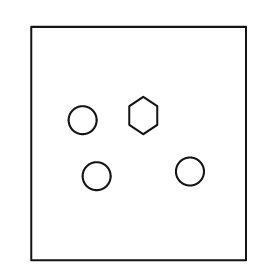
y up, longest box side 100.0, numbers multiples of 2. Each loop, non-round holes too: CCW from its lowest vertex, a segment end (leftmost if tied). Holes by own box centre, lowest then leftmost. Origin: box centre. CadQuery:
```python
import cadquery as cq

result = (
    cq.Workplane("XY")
    .moveTo(-46.0, -50.0)
    .lineTo(46.0, -50.0)
    .lineTo(46.0, 50.0)
    .lineTo(-46.0, 50.0)
    .close()
    .moveTo(-18.0, -14.0)
    .circle(6.0)
    .moveTo(22.0, -12.0)
    .circle(6.0)
    .moveTo(-24.0, 10.0)
    .circle(6.0)
    .moveTo(2.0, 4.0)
    .lineTo(8.0, 8.0)
    .lineTo(8.0, 16.0)
    .lineTo(2.0, 20.0)
    .lineTo(-4.0, 16.0)
    .lineTo(-4.0, 8.0)
    .close()
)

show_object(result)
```